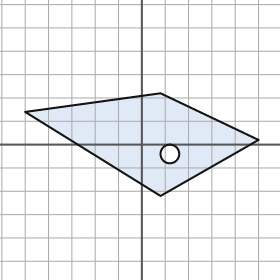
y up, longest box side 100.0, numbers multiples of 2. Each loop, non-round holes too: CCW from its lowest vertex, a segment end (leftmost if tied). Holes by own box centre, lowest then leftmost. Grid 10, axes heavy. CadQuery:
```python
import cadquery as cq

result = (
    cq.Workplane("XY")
    .moveTo(8.0, -22.0)
    .lineTo(50.0, 2.0)
    .lineTo(8.0, 22.0)
    .lineTo(-50.0, 14.0)
    .close()
    .moveTo(12.0, -4.0)
    .circle(4.0)
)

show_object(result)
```